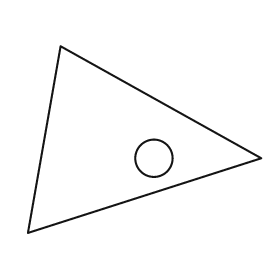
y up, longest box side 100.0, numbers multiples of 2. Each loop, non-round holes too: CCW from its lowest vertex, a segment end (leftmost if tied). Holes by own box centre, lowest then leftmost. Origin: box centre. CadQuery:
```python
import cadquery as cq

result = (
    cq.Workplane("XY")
    .moveTo(-50.0, -40.0)
    .lineTo(50.0, -8.0)
    .lineTo(-36.0, 40.0)
    .close()
    .moveTo(4.0, -8.0)
    .circle(8.0)
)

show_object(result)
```